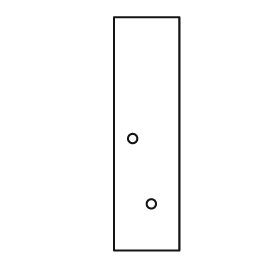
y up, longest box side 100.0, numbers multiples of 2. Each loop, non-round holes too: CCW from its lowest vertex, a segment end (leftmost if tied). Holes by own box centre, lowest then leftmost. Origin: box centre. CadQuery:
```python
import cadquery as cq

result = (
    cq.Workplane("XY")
    .moveTo(-14.0, -50.0)
    .lineTo(14.0, -50.0)
    .lineTo(14.0, 50.0)
    .lineTo(-14.0, 50.0)
    .close()
    .moveTo(2.0, -30.0)
    .circle(2.0)
    .moveTo(-6.0, -2.0)
    .circle(2.0)
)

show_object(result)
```